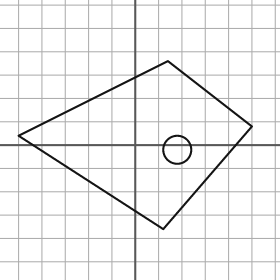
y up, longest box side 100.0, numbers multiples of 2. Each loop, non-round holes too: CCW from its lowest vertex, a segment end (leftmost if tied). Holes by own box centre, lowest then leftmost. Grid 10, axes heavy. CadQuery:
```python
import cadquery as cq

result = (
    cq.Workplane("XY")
    .moveTo(12.0, -36.0)
    .lineTo(50.0, 8.0)
    .lineTo(14.0, 36.0)
    .lineTo(-50.0, 4.0)
    .close()
    .moveTo(18.0, -2.0)
    .circle(6.0)
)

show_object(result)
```